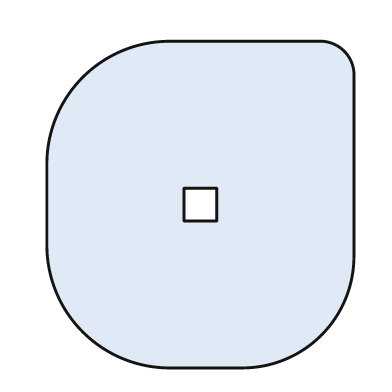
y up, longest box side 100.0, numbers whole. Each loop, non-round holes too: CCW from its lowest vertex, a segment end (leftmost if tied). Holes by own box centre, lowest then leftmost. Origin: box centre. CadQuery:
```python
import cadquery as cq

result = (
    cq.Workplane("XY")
    .moveTo(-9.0, -50.0)
    .lineTo(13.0, -50.0)
    .threePointArc((37.0, -40.0), (47.0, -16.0))
    .lineTo(47.0, 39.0)
    .threePointArc((44.0, 47.0), (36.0, 50.0))
    .lineTo(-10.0, 50.0)
    .threePointArc((-36.0, 39.0), (-47.0, 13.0))
    .lineTo(-47.0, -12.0)
    .threePointArc((-36.0, -39.0), (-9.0, -50.0))
    .close()
    .moveTo(-5.0, -5.0)
    .lineTo(5.0, -5.0)
    .lineTo(5.0, 5.0)
    .lineTo(-5.0, 5.0)
    .close()
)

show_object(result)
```